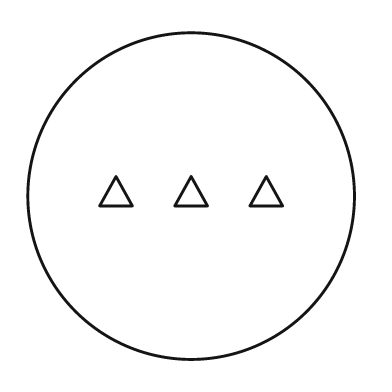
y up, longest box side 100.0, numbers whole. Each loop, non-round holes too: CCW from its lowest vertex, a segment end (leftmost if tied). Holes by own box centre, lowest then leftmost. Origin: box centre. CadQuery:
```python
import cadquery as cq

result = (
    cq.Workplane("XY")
    .moveTo(0.0, 0.0)
    .circle(50.0)
    .moveTo(-28.0, -3.0)
    .lineTo(-18.0, -3.0)
    .lineTo(-23.0, 6.0)
    .close()
    .moveTo(-5.0, -3.0)
    .lineTo(5.0, -3.0)
    .lineTo(0.0, 6.0)
    .close()
    .moveTo(18.0, -3.0)
    .lineTo(28.0, -3.0)
    .lineTo(23.0, 6.0)
    .close()
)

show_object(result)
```